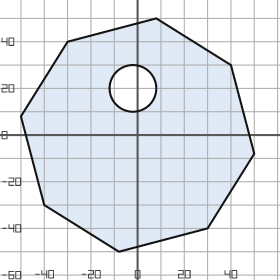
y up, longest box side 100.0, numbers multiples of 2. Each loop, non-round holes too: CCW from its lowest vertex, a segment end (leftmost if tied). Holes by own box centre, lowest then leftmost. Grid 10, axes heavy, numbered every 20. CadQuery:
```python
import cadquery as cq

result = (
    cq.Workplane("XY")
    .moveTo(-8.0, -50.0)
    .lineTo(30.0, -40.0)
    .lineTo(50.0, -8.0)
    .lineTo(40.0, 30.0)
    .lineTo(8.0, 50.0)
    .lineTo(-30.0, 40.0)
    .lineTo(-50.0, 8.0)
    .lineTo(-40.0, -30.0)
    .close()
    .moveTo(-2.0, 20.0)
    .circle(10.0)
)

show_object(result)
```